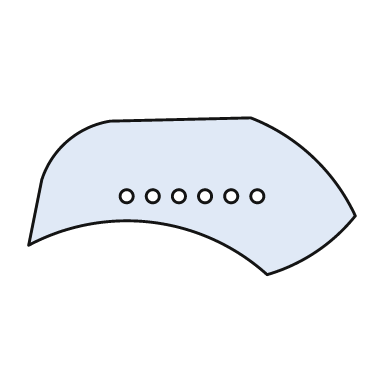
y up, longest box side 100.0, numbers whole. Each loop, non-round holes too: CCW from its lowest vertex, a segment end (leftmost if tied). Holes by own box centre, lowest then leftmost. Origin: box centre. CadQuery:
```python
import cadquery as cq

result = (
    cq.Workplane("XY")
    .moveTo(23.0, -24.0)
    .threePointArc((38.0, -17.0), (50.0, -6.0))
    .threePointArc((37.0, 12.0), (18.0, 24.0))
    .lineTo(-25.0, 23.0)
    .threePointArc((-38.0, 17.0), (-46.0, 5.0))
    .lineTo(-50.0, -15.0)
    .threePointArc((-12.0, -8.0), (23.0, -24.0))
    .close()
    .moveTo(-20.0, 0.0)
    .circle(2.0)
    .moveTo(-12.0, 0.0)
    .circle(2.0)
    .moveTo(-4.0, 0.0)
    .circle(2.0)
    .moveTo(4.0, 0.0)
    .circle(2.0)
    .moveTo(12.0, 0.0)
    .circle(2.0)
    .moveTo(20.0, 0.0)
    .circle(2.0)
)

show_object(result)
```